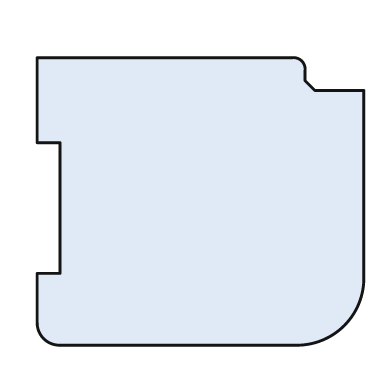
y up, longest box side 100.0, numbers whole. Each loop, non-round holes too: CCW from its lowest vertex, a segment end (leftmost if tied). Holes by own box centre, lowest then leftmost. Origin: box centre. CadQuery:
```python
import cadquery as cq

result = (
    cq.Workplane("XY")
    .moveTo(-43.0, -44.0)
    .lineTo(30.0, -44.0)
    .threePointArc((44.0, -38.0), (50.0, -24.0))
    .lineTo(50.0, 34.0)
    .lineTo(35.0, 34.0)
    .lineTo(32.0, 37.0)
    .lineTo(32.0, 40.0)
    .threePointArc((31.0, 43.0), (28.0, 44.0))
    .lineTo(-50.0, 44.0)
    .lineTo(-50.0, 18.0)
    .lineTo(-43.0, 18.0)
    .lineTo(-43.0, -22.0)
    .lineTo(-50.0, -22.0)
    .lineTo(-50.0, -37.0)
    .threePointArc((-48.0, -42.0), (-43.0, -44.0))
    .close()
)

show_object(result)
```